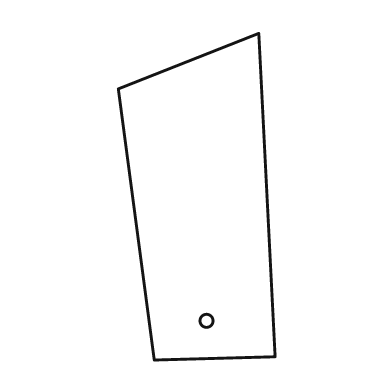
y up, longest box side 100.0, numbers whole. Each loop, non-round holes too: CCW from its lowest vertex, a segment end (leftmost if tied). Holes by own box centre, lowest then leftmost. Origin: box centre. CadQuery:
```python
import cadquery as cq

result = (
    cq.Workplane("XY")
    .moveTo(-13.0, -50.0)
    .lineTo(24.0, -49.0)
    .lineTo(19.0, 50.0)
    .lineTo(-24.0, 33.0)
    .close()
    .moveTo(3.0, -38.0)
    .circle(2.0)
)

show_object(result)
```